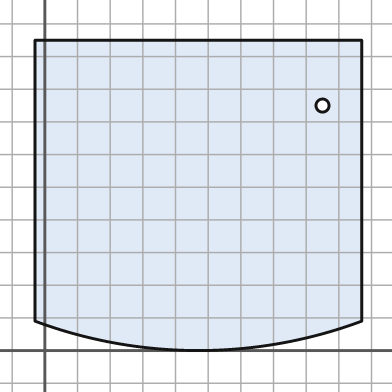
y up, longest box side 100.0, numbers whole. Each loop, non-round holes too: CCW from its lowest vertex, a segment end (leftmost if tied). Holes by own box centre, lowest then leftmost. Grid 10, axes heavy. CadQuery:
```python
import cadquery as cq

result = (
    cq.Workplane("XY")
    .moveTo(-3.0, 9.0)
    .threePointArc((47.0, 0.0), (97.0, 9.0))
    .lineTo(97.0, 95.0)
    .lineTo(-3.0, 95.0)
    .close()
    .moveTo(85.0, 75.0)
    .circle(2.0)
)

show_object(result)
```